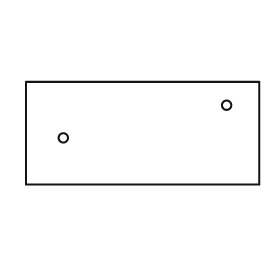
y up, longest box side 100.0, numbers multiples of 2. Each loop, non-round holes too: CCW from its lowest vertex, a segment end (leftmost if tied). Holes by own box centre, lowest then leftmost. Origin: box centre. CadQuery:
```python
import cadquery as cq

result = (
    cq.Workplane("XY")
    .moveTo(-50.0, -22.0)
    .lineTo(50.0, -22.0)
    .lineTo(50.0, 22.0)
    .lineTo(-50.0, 22.0)
    .close()
    .moveTo(-34.0, -2.0)
    .circle(2.0)
    .moveTo(36.0, 12.0)
    .circle(2.0)
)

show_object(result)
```